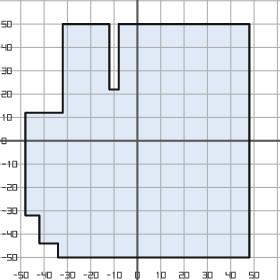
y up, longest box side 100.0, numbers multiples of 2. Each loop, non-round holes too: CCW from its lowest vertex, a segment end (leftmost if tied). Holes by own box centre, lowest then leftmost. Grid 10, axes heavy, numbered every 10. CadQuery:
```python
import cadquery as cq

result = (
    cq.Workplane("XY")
    .moveTo(-34.0, -50.0)
    .lineTo(48.0, -50.0)
    .lineTo(48.0, 50.0)
    .lineTo(-8.0, 50.0)
    .lineTo(-8.0, 22.0)
    .lineTo(-12.0, 22.0)
    .lineTo(-12.0, 50.0)
    .lineTo(-32.0, 50.0)
    .lineTo(-32.0, 12.0)
    .lineTo(-48.0, 12.0)
    .lineTo(-48.0, -32.0)
    .lineTo(-42.0, -32.0)
    .lineTo(-42.0, -44.0)
    .lineTo(-34.0, -44.0)
    .close()
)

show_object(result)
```